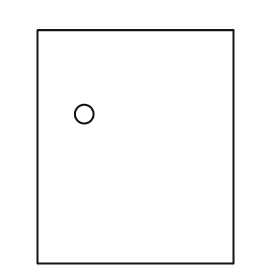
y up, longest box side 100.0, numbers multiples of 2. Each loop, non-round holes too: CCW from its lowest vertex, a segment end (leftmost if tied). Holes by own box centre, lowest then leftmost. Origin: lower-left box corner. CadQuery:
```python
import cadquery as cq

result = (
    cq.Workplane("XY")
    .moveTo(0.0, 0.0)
    .lineTo(84.0, 0.0)
    .lineTo(84.0, 100.0)
    .lineTo(0.0, 100.0)
    .close()
    .moveTo(20.0, 64.0)
    .circle(4.0)
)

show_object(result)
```